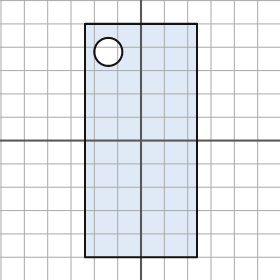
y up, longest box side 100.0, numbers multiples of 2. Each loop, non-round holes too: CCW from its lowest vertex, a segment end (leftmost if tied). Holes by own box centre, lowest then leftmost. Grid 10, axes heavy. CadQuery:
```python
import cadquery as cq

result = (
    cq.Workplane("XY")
    .moveTo(-24.0, -50.0)
    .lineTo(24.0, -50.0)
    .lineTo(24.0, 50.0)
    .lineTo(-24.0, 50.0)
    .close()
    .moveTo(-14.0, 38.0)
    .circle(6.0)
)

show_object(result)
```